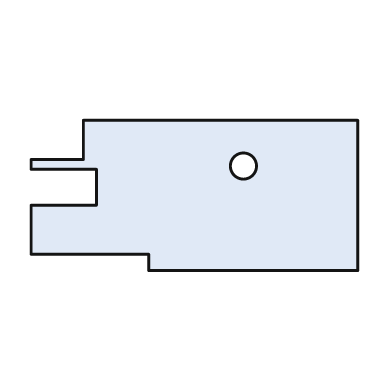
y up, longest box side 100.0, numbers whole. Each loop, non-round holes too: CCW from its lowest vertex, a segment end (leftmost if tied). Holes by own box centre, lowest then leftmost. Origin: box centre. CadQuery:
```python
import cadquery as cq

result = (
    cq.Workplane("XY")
    .moveTo(-14.0, -23.0)
    .lineTo(50.0, -23.0)
    .lineTo(50.0, 23.0)
    .lineTo(-34.0, 23.0)
    .lineTo(-34.0, 11.0)
    .lineTo(-50.0, 11.0)
    .lineTo(-50.0, 8.0)
    .lineTo(-30.0, 8.0)
    .lineTo(-30.0, -3.0)
    .lineTo(-50.0, -3.0)
    .lineTo(-50.0, -18.0)
    .lineTo(-14.0, -18.0)
    .close()
    .moveTo(15.0, 9.0)
    .circle(4.0)
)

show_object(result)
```